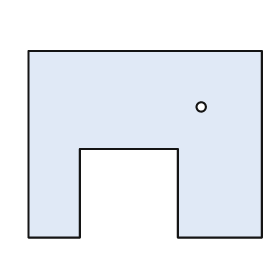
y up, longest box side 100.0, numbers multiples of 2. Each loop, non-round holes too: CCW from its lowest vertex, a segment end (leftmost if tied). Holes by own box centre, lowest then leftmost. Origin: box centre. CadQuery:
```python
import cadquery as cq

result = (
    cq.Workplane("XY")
    .moveTo(-50.0, -40.0)
    .lineTo(-28.0, -40.0)
    .lineTo(-28.0, -2.0)
    .lineTo(14.0, -2.0)
    .lineTo(14.0, -40.0)
    .lineTo(50.0, -40.0)
    .lineTo(50.0, 40.0)
    .lineTo(-50.0, 40.0)
    .close()
    .moveTo(24.0, 16.0)
    .circle(2.0)
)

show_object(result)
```